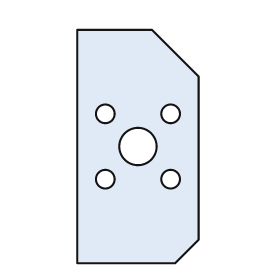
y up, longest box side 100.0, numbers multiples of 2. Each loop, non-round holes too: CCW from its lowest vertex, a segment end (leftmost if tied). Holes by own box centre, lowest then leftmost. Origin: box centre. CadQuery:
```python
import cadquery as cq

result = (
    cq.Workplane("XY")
    .moveTo(-26.0, -50.0)
    .lineTo(16.0, -50.0)
    .lineTo(26.0, -40.0)
    .lineTo(26.0, 30.0)
    .lineTo(6.0, 50.0)
    .lineTo(-26.0, 50.0)
    .close()
    .moveTo(-14.0, -14.0)
    .circle(4.0)
    .moveTo(14.0, -14.0)
    .circle(4.0)
    .moveTo(0.0, 0.0)
    .circle(8.0)
    .moveTo(-14.0, 14.0)
    .circle(4.0)
    .moveTo(14.0, 14.0)
    .circle(4.0)
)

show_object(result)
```